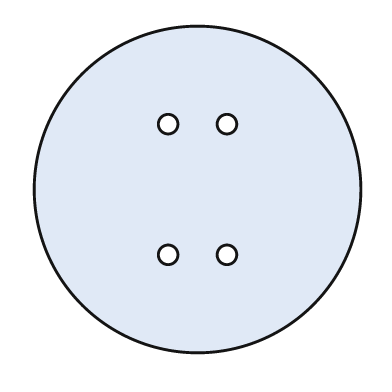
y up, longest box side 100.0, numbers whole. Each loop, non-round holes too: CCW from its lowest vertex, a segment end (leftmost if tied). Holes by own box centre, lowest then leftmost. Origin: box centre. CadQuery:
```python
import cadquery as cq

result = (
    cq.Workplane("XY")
    .moveTo(0.0, 0.0)
    .circle(50.0)
    .moveTo(-9.0, -20.0)
    .circle(3.0)
    .moveTo(9.0, -20.0)
    .circle(3.0)
    .moveTo(-9.0, 20.0)
    .circle(3.0)
    .moveTo(9.0, 20.0)
    .circle(3.0)
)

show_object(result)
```